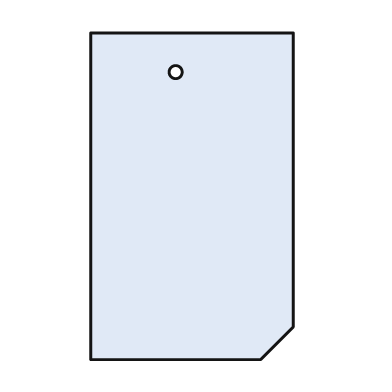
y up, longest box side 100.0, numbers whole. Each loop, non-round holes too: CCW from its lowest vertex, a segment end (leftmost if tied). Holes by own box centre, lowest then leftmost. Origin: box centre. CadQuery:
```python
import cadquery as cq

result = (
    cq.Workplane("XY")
    .moveTo(-31.0, -50.0)
    .lineTo(21.0, -50.0)
    .lineTo(31.0, -40.0)
    .lineTo(31.0, 50.0)
    .lineTo(-31.0, 50.0)
    .close()
    .moveTo(-5.0, 38.0)
    .circle(2.0)
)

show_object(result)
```